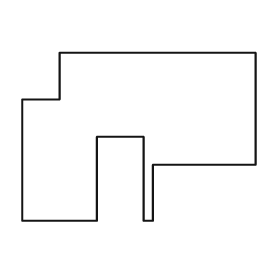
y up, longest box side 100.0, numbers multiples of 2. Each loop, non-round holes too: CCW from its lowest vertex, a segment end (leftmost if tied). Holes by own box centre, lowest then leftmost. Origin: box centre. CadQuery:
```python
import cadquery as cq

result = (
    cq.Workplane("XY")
    .moveTo(-50.0, -36.0)
    .lineTo(-18.0, -36.0)
    .lineTo(-18.0, 0.0)
    .lineTo(2.0, 0.0)
    .lineTo(2.0, -36.0)
    .lineTo(6.0, -36.0)
    .lineTo(6.0, -12.0)
    .lineTo(50.0, -12.0)
    .lineTo(50.0, 36.0)
    .lineTo(-34.0, 36.0)
    .lineTo(-34.0, 16.0)
    .lineTo(-50.0, 16.0)
    .close()
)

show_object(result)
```